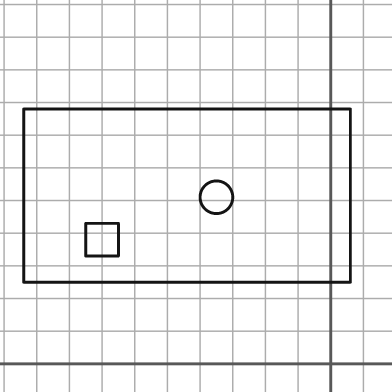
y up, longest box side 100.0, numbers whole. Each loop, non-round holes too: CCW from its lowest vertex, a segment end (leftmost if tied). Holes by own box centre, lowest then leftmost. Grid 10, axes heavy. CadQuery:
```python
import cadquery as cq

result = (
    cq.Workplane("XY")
    .moveTo(-94.0, 25.0)
    .lineTo(6.0, 25.0)
    .lineTo(6.0, 78.0)
    .lineTo(-94.0, 78.0)
    .close()
    .moveTo(-75.0, 33.0)
    .lineTo(-65.0, 33.0)
    .lineTo(-65.0, 43.0)
    .lineTo(-75.0, 43.0)
    .close()
    .moveTo(-35.0, 51.0)
    .circle(5.0)
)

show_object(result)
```